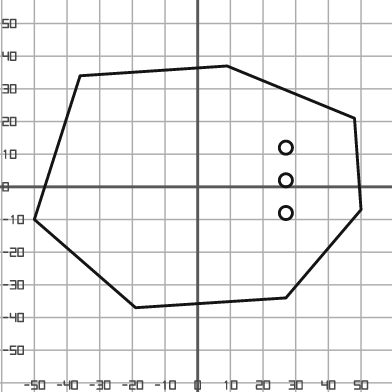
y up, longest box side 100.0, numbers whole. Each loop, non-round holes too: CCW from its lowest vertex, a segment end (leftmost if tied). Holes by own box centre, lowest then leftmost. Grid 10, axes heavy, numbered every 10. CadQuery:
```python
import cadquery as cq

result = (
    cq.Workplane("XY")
    .moveTo(-19.0, -37.0)
    .lineTo(27.0, -34.0)
    .lineTo(50.0, -7.0)
    .lineTo(48.0, 21.0)
    .lineTo(9.0, 37.0)
    .lineTo(-36.0, 34.0)
    .lineTo(-50.0, -10.0)
    .close()
    .moveTo(27.0, -8.0)
    .circle(2.0)
    .moveTo(27.0, 2.0)
    .circle(2.0)
    .moveTo(27.0, 12.0)
    .circle(2.0)
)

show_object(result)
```